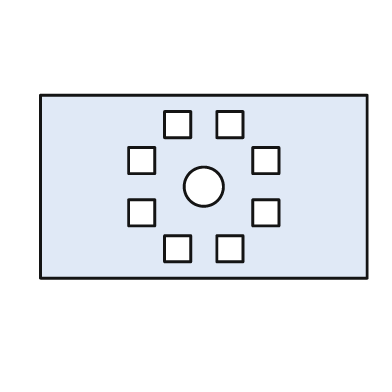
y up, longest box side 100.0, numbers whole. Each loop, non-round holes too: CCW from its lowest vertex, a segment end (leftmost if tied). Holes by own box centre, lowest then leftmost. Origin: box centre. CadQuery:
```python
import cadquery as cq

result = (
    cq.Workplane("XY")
    .moveTo(-50.0, -28.0)
    .lineTo(50.0, -28.0)
    .lineTo(50.0, 28.0)
    .lineTo(-50.0, 28.0)
    .close()
    .moveTo(-12.0, -23.0)
    .lineTo(-4.0, -23.0)
    .lineTo(-4.0, -15.0)
    .lineTo(-12.0, -15.0)
    .close()
    .moveTo(4.0, -23.0)
    .lineTo(12.0, -23.0)
    .lineTo(12.0, -15.0)
    .lineTo(4.0, -15.0)
    .close()
    .moveTo(-23.0, -12.0)
    .lineTo(-15.0, -12.0)
    .lineTo(-15.0, -4.0)
    .lineTo(-23.0, -4.0)
    .close()
    .moveTo(15.0, -12.0)
    .lineTo(23.0, -12.0)
    .lineTo(23.0, -4.0)
    .lineTo(15.0, -4.0)
    .close()
    .moveTo(0.0, 0.0)
    .circle(6.0)
    .moveTo(-23.0, 4.0)
    .lineTo(-15.0, 4.0)
    .lineTo(-15.0, 12.0)
    .lineTo(-23.0, 12.0)
    .close()
    .moveTo(15.0, 4.0)
    .lineTo(23.0, 4.0)
    .lineTo(23.0, 12.0)
    .lineTo(15.0, 12.0)
    .close()
    .moveTo(-12.0, 15.0)
    .lineTo(-4.0, 15.0)
    .lineTo(-4.0, 23.0)
    .lineTo(-12.0, 23.0)
    .close()
    .moveTo(4.0, 15.0)
    .lineTo(12.0, 15.0)
    .lineTo(12.0, 23.0)
    .lineTo(4.0, 23.0)
    .close()
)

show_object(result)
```